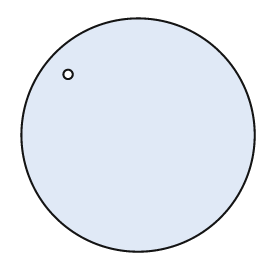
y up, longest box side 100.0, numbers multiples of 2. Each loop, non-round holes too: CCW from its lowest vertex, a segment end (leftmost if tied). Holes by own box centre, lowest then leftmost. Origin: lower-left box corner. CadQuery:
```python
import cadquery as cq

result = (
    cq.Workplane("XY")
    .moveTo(50.0, 50.0)
    .circle(50.0)
    .moveTo(20.0, 76.0)
    .circle(2.0)
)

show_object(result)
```